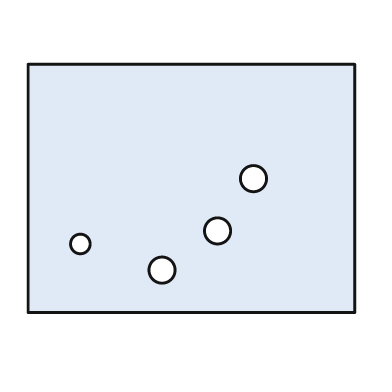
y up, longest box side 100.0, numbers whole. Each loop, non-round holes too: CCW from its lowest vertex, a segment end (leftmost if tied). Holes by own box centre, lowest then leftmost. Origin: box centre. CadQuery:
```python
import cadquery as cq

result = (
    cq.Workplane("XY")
    .moveTo(-50.0, -38.0)
    .lineTo(50.0, -38.0)
    .lineTo(50.0, 38.0)
    .lineTo(-50.0, 38.0)
    .close()
    .moveTo(-9.0, -25.0)
    .circle(4.0)
    .moveTo(-34.0, -17.0)
    .circle(3.0)
    .moveTo(8.0, -13.0)
    .circle(4.0)
    .moveTo(19.0, 3.0)
    .circle(4.0)
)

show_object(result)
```